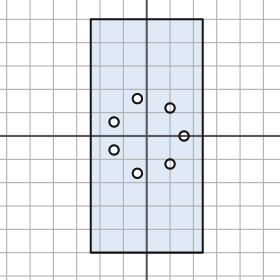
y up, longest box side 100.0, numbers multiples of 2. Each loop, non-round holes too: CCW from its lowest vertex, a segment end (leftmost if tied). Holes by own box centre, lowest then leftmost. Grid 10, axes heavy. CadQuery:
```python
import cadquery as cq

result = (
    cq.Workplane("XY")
    .moveTo(-24.0, -50.0)
    .lineTo(24.0, -50.0)
    .lineTo(24.0, 50.0)
    .lineTo(-24.0, 50.0)
    .close()
    .moveTo(-4.0, -16.0)
    .circle(2.0)
    .moveTo(10.0, -12.0)
    .circle(2.0)
    .moveTo(-14.0, -6.0)
    .circle(2.0)
    .moveTo(16.0, 0.0)
    .circle(2.0)
    .moveTo(-14.0, 6.0)
    .circle(2.0)
    .moveTo(10.0, 12.0)
    .circle(2.0)
    .moveTo(-4.0, 16.0)
    .circle(2.0)
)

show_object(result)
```